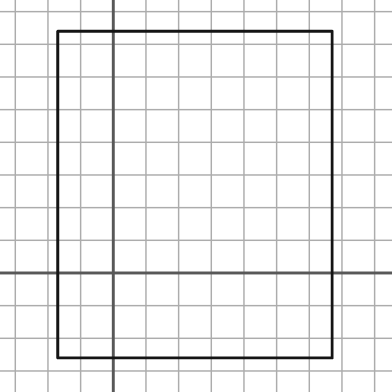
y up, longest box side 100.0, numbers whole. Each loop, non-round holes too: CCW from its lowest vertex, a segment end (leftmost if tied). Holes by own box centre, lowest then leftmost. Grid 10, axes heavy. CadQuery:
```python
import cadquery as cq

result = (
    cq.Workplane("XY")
    .moveTo(-17.0, -26.0)
    .lineTo(67.0, -26.0)
    .lineTo(67.0, 74.0)
    .lineTo(-17.0, 74.0)
    .close()
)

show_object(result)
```